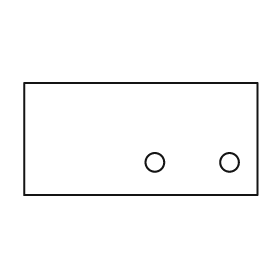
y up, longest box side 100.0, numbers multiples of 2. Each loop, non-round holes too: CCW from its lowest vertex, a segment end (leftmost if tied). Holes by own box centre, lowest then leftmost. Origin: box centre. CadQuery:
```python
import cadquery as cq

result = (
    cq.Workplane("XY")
    .moveTo(-50.0, -24.0)
    .lineTo(50.0, -24.0)
    .lineTo(50.0, 24.0)
    .lineTo(-50.0, 24.0)
    .close()
    .moveTo(6.0, -10.0)
    .circle(4.0)
    .moveTo(38.0, -10.0)
    .circle(4.0)
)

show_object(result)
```